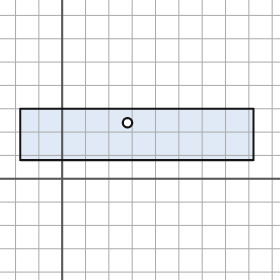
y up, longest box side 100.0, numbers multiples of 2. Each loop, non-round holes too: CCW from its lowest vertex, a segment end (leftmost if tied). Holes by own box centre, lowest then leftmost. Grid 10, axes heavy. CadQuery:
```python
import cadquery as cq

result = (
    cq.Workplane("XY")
    .moveTo(-18.0, 8.0)
    .lineTo(82.0, 8.0)
    .lineTo(82.0, 30.0)
    .lineTo(-18.0, 30.0)
    .close()
    .moveTo(28.0, 24.0)
    .circle(2.0)
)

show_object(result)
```